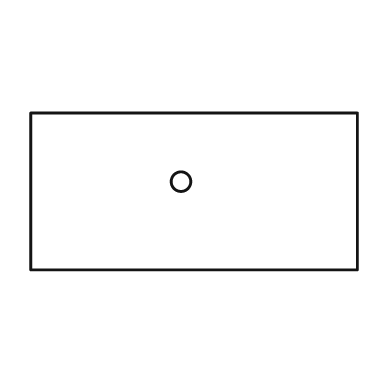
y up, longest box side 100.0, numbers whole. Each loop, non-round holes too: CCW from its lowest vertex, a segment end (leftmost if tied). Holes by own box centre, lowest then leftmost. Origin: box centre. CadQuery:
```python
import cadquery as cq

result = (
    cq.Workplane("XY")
    .moveTo(-50.0, -24.0)
    .lineTo(50.0, -24.0)
    .lineTo(50.0, 24.0)
    .lineTo(-50.0, 24.0)
    .close()
    .moveTo(-4.0, 3.0)
    .circle(3.0)
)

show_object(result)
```